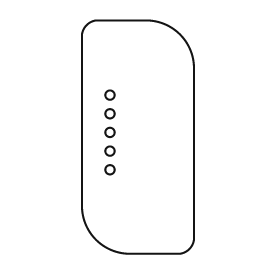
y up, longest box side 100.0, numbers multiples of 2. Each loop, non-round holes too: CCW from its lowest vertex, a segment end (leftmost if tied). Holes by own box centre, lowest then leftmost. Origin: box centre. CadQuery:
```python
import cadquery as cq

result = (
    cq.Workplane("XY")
    .moveTo(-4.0, -50.0)
    .lineTo(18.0, -50.0)
    .threePointArc((22.0, -48.0), (24.0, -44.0))
    .lineTo(24.0, 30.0)
    .threePointArc((18.0, 44.0), (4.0, 50.0))
    .lineTo(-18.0, 50.0)
    .threePointArc((-22.0, 48.0), (-24.0, 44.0))
    .lineTo(-24.0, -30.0)
    .threePointArc((-18.0, -44.0), (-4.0, -50.0))
    .close()
    .moveTo(-12.0, -14.0)
    .circle(2.0)
    .moveTo(-12.0, -6.0)
    .circle(2.0)
    .moveTo(-12.0, 2.0)
    .circle(2.0)
    .moveTo(-12.0, 10.0)
    .circle(2.0)
    .moveTo(-12.0, 18.0)
    .circle(2.0)
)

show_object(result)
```